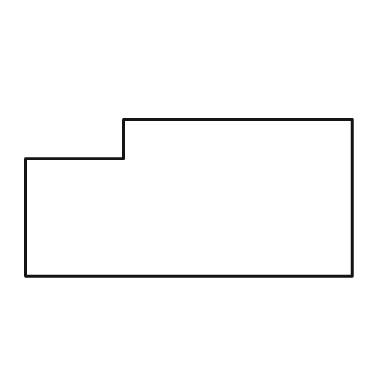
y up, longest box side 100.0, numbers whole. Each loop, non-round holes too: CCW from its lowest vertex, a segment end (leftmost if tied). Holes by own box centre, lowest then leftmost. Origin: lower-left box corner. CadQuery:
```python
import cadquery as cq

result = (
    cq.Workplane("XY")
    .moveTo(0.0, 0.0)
    .lineTo(100.0, 0.0)
    .lineTo(100.0, 48.0)
    .lineTo(30.0, 48.0)
    .lineTo(30.0, 36.0)
    .lineTo(0.0, 36.0)
    .close()
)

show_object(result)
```